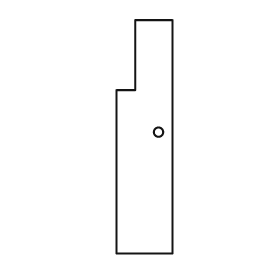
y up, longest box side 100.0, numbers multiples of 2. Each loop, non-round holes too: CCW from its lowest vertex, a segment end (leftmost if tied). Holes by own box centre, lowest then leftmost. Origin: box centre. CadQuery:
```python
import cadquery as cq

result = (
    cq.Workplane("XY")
    .moveTo(-12.0, -50.0)
    .lineTo(12.0, -50.0)
    .lineTo(12.0, 50.0)
    .lineTo(-4.0, 50.0)
    .lineTo(-4.0, 20.0)
    .lineTo(-12.0, 20.0)
    .close()
    .moveTo(6.0, 2.0)
    .circle(2.0)
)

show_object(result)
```